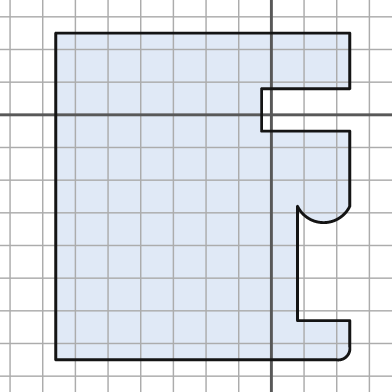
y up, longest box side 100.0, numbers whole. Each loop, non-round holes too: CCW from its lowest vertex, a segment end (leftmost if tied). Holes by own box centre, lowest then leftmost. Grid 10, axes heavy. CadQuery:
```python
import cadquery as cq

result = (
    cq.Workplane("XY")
    .moveTo(-66.0, -75.0)
    .lineTo(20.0, -75.0)
    .threePointArc((23.0, -74.0), (24.0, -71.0))
    .lineTo(24.0, -63.0)
    .lineTo(8.0, -63.0)
    .lineTo(8.0, -28.0)
    .threePointArc((16.0, -33.0), (24.0, -28.0))
    .lineTo(24.0, -5.0)
    .lineTo(-3.0, -5.0)
    .lineTo(-3.0, 8.0)
    .lineTo(24.0, 8.0)
    .lineTo(24.0, 25.0)
    .lineTo(-66.0, 25.0)
    .close()
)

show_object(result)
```